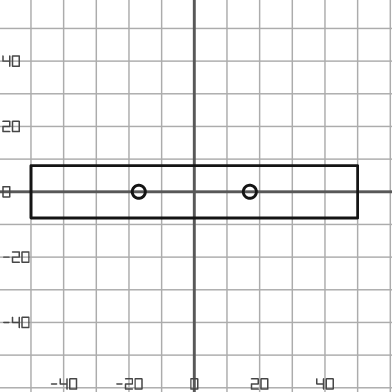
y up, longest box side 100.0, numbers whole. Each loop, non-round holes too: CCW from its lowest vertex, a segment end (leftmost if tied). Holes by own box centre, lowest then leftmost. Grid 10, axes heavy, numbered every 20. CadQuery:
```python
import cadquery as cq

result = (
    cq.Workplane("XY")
    .moveTo(-50.0, -8.0)
    .lineTo(50.0, -8.0)
    .lineTo(50.0, 8.0)
    .lineTo(-50.0, 8.0)
    .close()
    .moveTo(-17.0, 0.0)
    .circle(2.0)
    .moveTo(17.0, 0.0)
    .circle(2.0)
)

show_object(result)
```